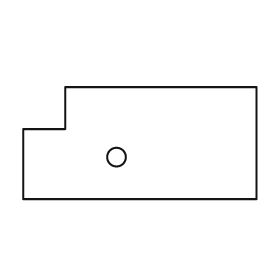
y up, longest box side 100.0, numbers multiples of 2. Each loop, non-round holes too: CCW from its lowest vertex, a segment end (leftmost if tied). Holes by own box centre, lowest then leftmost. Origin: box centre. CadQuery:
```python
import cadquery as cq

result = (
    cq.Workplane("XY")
    .moveTo(-50.0, -24.0)
    .lineTo(50.0, -24.0)
    .lineTo(50.0, 24.0)
    .lineTo(-32.0, 24.0)
    .lineTo(-32.0, 6.0)
    .lineTo(-50.0, 6.0)
    .close()
    .moveTo(-10.0, -6.0)
    .circle(4.0)
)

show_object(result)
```